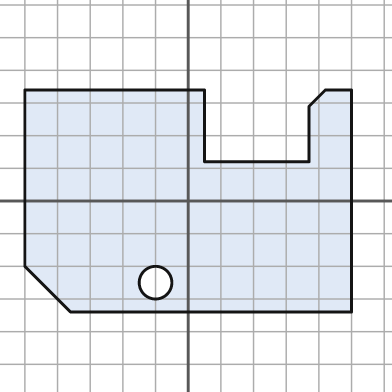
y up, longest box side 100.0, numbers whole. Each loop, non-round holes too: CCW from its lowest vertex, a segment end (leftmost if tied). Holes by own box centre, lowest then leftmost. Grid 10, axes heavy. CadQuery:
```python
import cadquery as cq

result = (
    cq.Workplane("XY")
    .moveTo(-36.0, -34.0)
    .lineTo(50.0, -34.0)
    .lineTo(50.0, 34.0)
    .lineTo(42.0, 34.0)
    .lineTo(37.0, 29.0)
    .lineTo(37.0, 12.0)
    .lineTo(5.0, 12.0)
    .lineTo(5.0, 34.0)
    .lineTo(-50.0, 34.0)
    .lineTo(-50.0, -20.0)
    .close()
    .moveTo(-10.0, -25.0)
    .circle(5.0)
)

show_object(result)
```